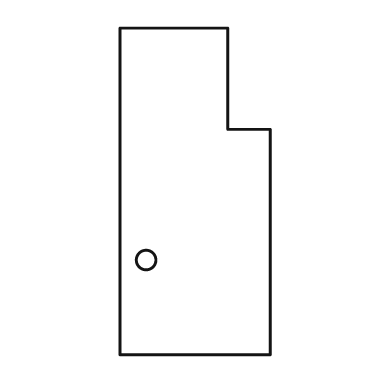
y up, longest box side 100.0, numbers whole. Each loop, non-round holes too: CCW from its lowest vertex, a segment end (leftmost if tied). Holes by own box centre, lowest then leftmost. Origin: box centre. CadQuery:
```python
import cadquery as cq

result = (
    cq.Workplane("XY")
    .moveTo(-23.0, -50.0)
    .lineTo(23.0, -50.0)
    .lineTo(23.0, 19.0)
    .lineTo(10.0, 19.0)
    .lineTo(10.0, 50.0)
    .lineTo(-23.0, 50.0)
    .close()
    .moveTo(-15.0, -21.0)
    .circle(3.0)
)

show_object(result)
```